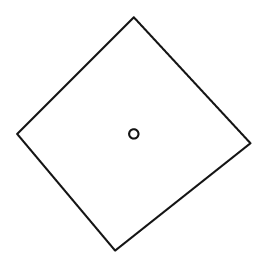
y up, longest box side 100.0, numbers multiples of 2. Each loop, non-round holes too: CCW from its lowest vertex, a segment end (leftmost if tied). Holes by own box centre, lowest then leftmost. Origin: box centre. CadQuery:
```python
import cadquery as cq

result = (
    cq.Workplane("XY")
    .moveTo(-8.0, -50.0)
    .lineTo(50.0, -4.0)
    .lineTo(0.0, 50.0)
    .lineTo(-50.0, 0.0)
    .close()
    .moveTo(0.0, 0.0)
    .circle(2.0)
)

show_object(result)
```